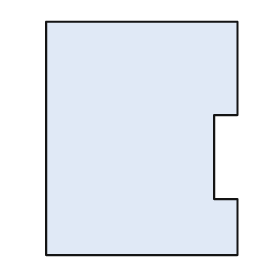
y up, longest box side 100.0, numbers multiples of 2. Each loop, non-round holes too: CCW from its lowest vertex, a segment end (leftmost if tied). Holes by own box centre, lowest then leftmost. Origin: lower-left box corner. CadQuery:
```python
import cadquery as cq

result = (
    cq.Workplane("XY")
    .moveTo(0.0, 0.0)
    .lineTo(82.0, 0.0)
    .lineTo(82.0, 24.0)
    .lineTo(72.0, 24.0)
    .lineTo(72.0, 60.0)
    .lineTo(82.0, 60.0)
    .lineTo(82.0, 100.0)
    .lineTo(0.0, 100.0)
    .close()
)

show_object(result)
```